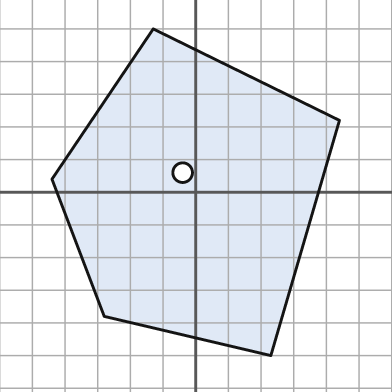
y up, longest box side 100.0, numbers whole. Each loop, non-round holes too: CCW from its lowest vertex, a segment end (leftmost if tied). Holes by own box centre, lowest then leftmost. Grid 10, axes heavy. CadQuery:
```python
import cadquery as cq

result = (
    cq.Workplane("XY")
    .moveTo(23.0, -50.0)
    .lineTo(44.0, 22.0)
    .lineTo(-13.0, 50.0)
    .lineTo(-44.0, 4.0)
    .lineTo(-28.0, -38.0)
    .close()
    .moveTo(-4.0, 6.0)
    .circle(3.0)
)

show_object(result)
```